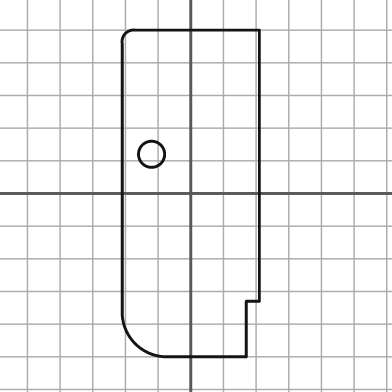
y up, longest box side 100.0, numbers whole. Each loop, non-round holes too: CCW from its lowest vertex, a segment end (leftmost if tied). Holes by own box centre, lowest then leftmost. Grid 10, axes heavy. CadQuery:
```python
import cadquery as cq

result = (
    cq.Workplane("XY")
    .moveTo(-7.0, -50.0)
    .lineTo(17.0, -50.0)
    .lineTo(17.0, -33.0)
    .lineTo(21.0, -33.0)
    .lineTo(21.0, 50.0)
    .lineTo(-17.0, 50.0)
    .threePointArc((-20.0, 49.0), (-21.0, 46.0))
    .lineTo(-21.0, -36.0)
    .threePointArc((-17.0, -46.0), (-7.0, -50.0))
    .close()
    .moveTo(-12.0, 12.0)
    .circle(4.0)
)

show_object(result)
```